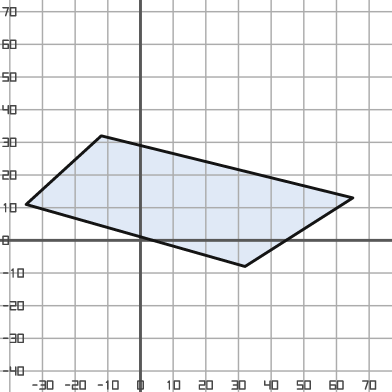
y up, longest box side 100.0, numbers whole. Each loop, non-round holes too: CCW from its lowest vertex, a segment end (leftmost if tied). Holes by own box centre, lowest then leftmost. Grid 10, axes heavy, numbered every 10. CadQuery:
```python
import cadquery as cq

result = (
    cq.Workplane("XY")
    .moveTo(32.0, -8.0)
    .lineTo(65.0, 13.0)
    .lineTo(-12.0, 32.0)
    .lineTo(-35.0, 11.0)
    .close()
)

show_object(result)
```